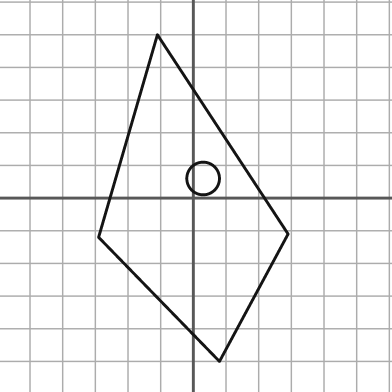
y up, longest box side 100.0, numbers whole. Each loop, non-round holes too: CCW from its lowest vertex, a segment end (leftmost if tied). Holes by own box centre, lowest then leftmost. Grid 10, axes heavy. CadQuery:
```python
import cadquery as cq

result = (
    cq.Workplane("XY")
    .moveTo(8.0, -50.0)
    .lineTo(29.0, -11.0)
    .lineTo(-11.0, 50.0)
    .lineTo(-29.0, -12.0)
    .close()
    .moveTo(3.0, 6.0)
    .circle(5.0)
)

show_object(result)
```